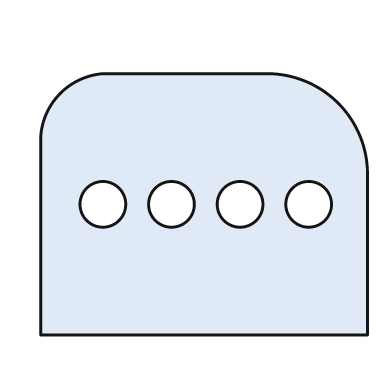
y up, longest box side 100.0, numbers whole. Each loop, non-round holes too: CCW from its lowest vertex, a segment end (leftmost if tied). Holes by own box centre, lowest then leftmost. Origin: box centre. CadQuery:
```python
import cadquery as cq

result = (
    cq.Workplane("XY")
    .moveTo(-50.0, -40.0)
    .lineTo(50.0, -40.0)
    .lineTo(50.0, 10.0)
    .threePointArc((41.0, 31.0), (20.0, 40.0))
    .lineTo(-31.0, 40.0)
    .threePointArc((-44.0, 34.0), (-50.0, 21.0))
    .close()
    .moveTo(-31.0, 0.0)
    .circle(7.0)
    .moveTo(-10.0, 0.0)
    .circle(7.0)
    .moveTo(11.0, 0.0)
    .circle(7.0)
    .moveTo(32.0, 0.0)
    .circle(7.0)
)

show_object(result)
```